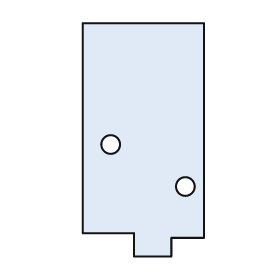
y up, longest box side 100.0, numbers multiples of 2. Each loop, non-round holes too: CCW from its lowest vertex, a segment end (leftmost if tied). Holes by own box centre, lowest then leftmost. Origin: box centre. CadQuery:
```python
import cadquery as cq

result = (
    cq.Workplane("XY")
    .moveTo(-4.0, -50.0)
    .lineTo(12.0, -50.0)
    .lineTo(12.0, -42.0)
    .lineTo(26.0, -42.0)
    .lineTo(26.0, 50.0)
    .lineTo(-26.0, 50.0)
    .lineTo(-26.0, -40.0)
    .lineTo(-4.0, -40.0)
    .close()
    .moveTo(18.0, -20.0)
    .circle(4.0)
    .moveTo(-14.0, -2.0)
    .circle(4.0)
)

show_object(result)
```